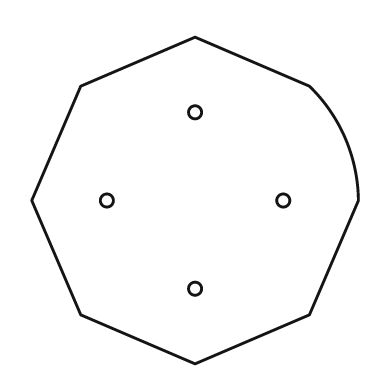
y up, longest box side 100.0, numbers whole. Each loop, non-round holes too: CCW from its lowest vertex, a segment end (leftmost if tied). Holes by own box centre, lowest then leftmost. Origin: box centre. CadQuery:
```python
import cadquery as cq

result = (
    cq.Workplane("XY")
    .moveTo(0.0, -50.0)
    .lineTo(35.0, -35.0)
    .lineTo(50.0, 0.0)
    .threePointArc((46.0, 19.0), (35.0, 35.0))
    .lineTo(0.0, 50.0)
    .lineTo(-35.0, 35.0)
    .lineTo(-50.0, 0.0)
    .lineTo(-35.0, -35.0)
    .close()
    .moveTo(0.0, -27.0)
    .circle(2.0)
    .moveTo(-27.0, 0.0)
    .circle(2.0)
    .moveTo(27.0, 0.0)
    .circle(2.0)
    .moveTo(0.0, 27.0)
    .circle(2.0)
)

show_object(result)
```